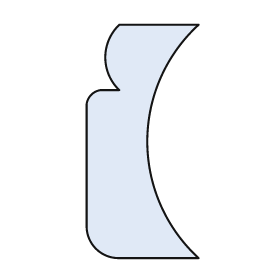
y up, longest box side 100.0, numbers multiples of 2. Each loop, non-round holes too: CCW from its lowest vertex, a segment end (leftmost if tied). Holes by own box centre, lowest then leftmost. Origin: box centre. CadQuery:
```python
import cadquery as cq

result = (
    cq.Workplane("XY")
    .moveTo(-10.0, -50.0)
    .lineTo(24.0, -50.0)
    .threePointArc((2.0, 0.0), (24.0, 50.0))
    .lineTo(-10.0, 50.0)
    .threePointArc((-16.0, 36.0), (-10.0, 22.0))
    .lineTo(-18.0, 22.0)
    .threePointArc((-22.0, 20.0), (-24.0, 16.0))
    .lineTo(-24.0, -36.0)
    .threePointArc((-20.0, -46.0), (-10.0, -50.0))
    .close()
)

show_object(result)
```